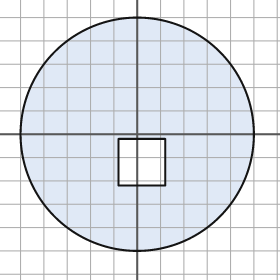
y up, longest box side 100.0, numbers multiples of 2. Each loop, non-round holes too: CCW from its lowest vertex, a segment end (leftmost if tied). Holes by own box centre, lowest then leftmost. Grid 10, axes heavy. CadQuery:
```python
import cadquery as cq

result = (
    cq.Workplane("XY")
    .moveTo(0.0, 0.0)
    .circle(50.0)
    .moveTo(-8.0, -22.0)
    .lineTo(12.0, -22.0)
    .lineTo(12.0, -2.0)
    .lineTo(-8.0, -2.0)
    .close()
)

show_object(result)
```